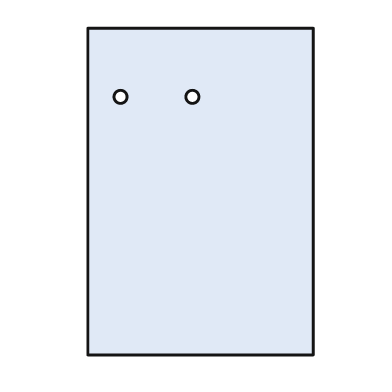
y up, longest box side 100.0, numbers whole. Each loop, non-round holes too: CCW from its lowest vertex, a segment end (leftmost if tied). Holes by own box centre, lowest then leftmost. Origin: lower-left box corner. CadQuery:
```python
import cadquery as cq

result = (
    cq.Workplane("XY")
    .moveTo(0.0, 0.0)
    .lineTo(69.0, 0.0)
    .lineTo(69.0, 100.0)
    .lineTo(0.0, 100.0)
    .close()
    .moveTo(10.0, 79.0)
    .circle(2.0)
    .moveTo(32.0, 79.0)
    .circle(2.0)
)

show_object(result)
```